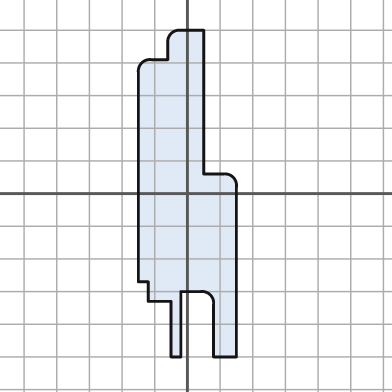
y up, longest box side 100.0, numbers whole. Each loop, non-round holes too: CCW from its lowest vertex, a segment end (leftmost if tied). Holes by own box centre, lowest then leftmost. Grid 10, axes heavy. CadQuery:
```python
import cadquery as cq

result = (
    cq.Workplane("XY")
    .moveTo(-5.0, -50.0)
    .lineTo(-2.0, -50.0)
    .lineTo(-2.0, -30.0)
    .lineTo(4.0, -30.0)
    .threePointArc((7.0, -31.0), (8.0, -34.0))
    .lineTo(8.0, -50.0)
    .lineTo(15.0, -50.0)
    .lineTo(15.0, 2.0)
    .threePointArc((14.0, 5.0), (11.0, 6.0))
    .lineTo(5.0, 6.0)
    .lineTo(5.0, 50.0)
    .lineTo(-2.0, 50.0)
    .threePointArc((-5.0, 49.0), (-6.0, 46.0))
    .lineTo(-6.0, 41.0)
    .lineTo(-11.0, 41.0)
    .threePointArc((-14.0, 40.0), (-15.0, 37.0))
    .lineTo(-15.0, -27.0)
    .lineTo(-12.0, -27.0)
    .lineTo(-12.0, -33.0)
    .lineTo(-5.0, -33.0)
    .close()
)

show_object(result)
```